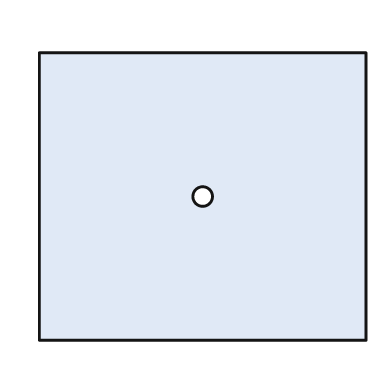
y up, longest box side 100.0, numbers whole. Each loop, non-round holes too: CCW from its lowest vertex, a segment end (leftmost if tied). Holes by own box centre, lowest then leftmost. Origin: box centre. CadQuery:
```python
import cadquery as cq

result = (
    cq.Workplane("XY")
    .moveTo(-50.0, -44.0)
    .lineTo(50.0, -44.0)
    .lineTo(50.0, 44.0)
    .lineTo(-50.0, 44.0)
    .close()
    .moveTo(0.0, 0.0)
    .circle(3.0)
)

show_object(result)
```